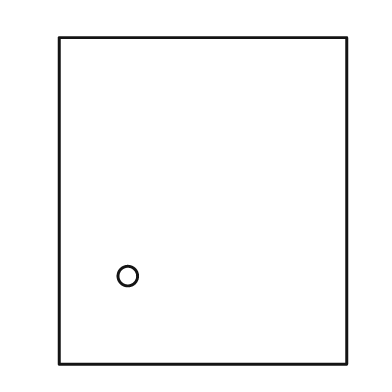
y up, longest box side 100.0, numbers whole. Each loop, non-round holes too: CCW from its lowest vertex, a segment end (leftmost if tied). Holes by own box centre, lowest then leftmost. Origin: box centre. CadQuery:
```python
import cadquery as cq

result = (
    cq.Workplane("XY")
    .moveTo(-44.0, -50.0)
    .lineTo(44.0, -50.0)
    .lineTo(44.0, 50.0)
    .lineTo(-44.0, 50.0)
    .close()
    .moveTo(-23.0, -23.0)
    .circle(3.0)
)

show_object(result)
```